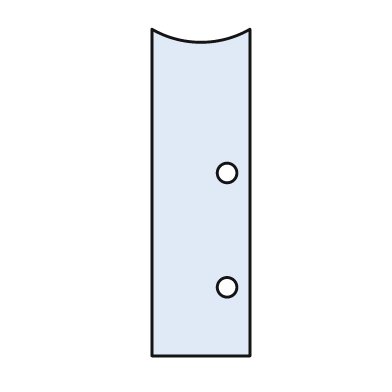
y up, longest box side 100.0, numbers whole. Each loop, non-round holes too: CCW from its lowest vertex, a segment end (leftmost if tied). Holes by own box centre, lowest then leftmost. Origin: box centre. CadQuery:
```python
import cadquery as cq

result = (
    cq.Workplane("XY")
    .moveTo(-15.0, -50.0)
    .lineTo(15.0, -50.0)
    .lineTo(15.0, 50.0)
    .threePointArc((0.0, 46.0), (-15.0, 50.0))
    .close()
    .moveTo(8.0, -29.0)
    .circle(3.0)
    .moveTo(8.0, 6.0)
    .circle(3.0)
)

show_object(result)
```